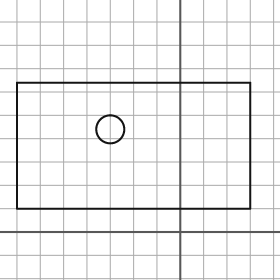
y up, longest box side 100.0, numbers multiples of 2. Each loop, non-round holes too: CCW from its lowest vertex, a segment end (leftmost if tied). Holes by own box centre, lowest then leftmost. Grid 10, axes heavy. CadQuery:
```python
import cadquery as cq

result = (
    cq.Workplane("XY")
    .moveTo(-70.0, 10.0)
    .lineTo(30.0, 10.0)
    .lineTo(30.0, 64.0)
    .lineTo(-70.0, 64.0)
    .close()
    .moveTo(-30.0, 44.0)
    .circle(6.0)
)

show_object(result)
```